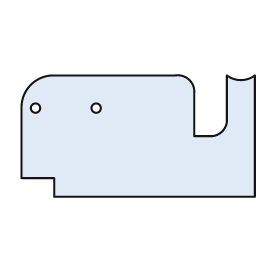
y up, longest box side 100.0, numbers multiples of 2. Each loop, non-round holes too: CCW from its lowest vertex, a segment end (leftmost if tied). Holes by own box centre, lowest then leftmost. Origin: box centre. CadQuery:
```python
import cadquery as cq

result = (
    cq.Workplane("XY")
    .moveTo(-36.0, -26.0)
    .lineTo(50.0, -26.0)
    .lineTo(50.0, 26.0)
    .threePointArc((44.0, 24.0), (38.0, 26.0))
    .lineTo(38.0, 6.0)
    .threePointArc((36.0, 2.0), (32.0, 0.0))
    .lineTo(24.0, 0.0)
    .lineTo(24.0, 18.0)
    .threePointArc((22.0, 24.0), (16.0, 26.0))
    .lineTo(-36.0, 26.0)
    .threePointArc((-46.0, 22.0), (-50.0, 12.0))
    .lineTo(-50.0, -18.0)
    .lineTo(-36.0, -18.0)
    .close()
    .moveTo(-44.0, 12.0)
    .circle(2.0)
    .moveTo(-18.0, 12.0)
    .circle(2.0)
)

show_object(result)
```